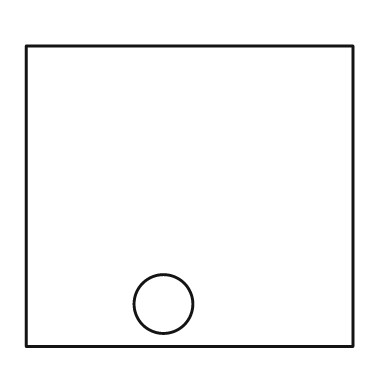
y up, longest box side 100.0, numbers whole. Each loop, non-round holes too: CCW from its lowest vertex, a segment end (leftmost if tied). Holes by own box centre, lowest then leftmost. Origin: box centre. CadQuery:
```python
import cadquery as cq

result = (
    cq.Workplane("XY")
    .moveTo(-50.0, -46.0)
    .lineTo(50.0, -46.0)
    .lineTo(50.0, 46.0)
    .lineTo(-50.0, 46.0)
    .close()
    .moveTo(-8.0, -33.0)
    .circle(9.0)
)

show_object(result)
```